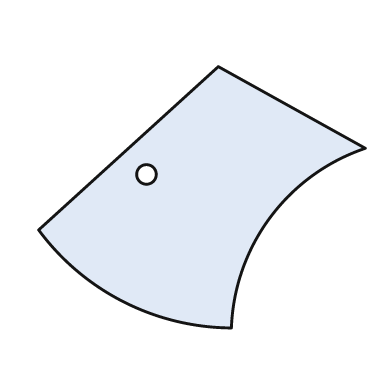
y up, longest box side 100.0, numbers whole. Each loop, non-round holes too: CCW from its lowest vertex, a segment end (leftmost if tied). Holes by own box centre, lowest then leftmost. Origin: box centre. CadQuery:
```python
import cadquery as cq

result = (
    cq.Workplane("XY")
    .moveTo(9.0, -40.0)
    .threePointArc((21.0, -6.0), (50.0, 15.0))
    .lineTo(5.0, 40.0)
    .lineTo(-50.0, -10.0)
    .threePointArc((-24.0, -32.0), (9.0, -40.0))
    .close()
    .moveTo(-17.0, 7.0)
    .circle(3.0)
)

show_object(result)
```